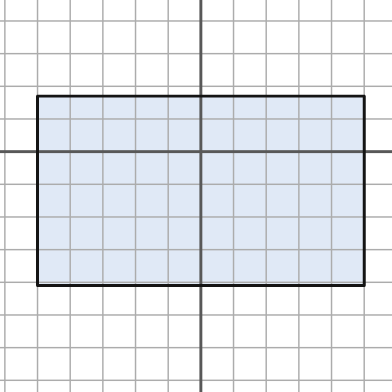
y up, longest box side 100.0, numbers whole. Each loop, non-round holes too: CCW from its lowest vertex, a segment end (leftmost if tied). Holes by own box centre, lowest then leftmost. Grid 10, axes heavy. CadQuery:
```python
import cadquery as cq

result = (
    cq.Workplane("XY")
    .moveTo(-50.0, -41.0)
    .lineTo(50.0, -41.0)
    .lineTo(50.0, 17.0)
    .lineTo(-50.0, 17.0)
    .close()
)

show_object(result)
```